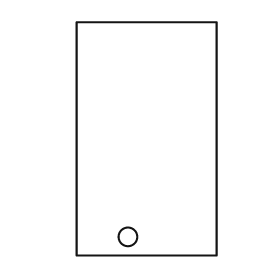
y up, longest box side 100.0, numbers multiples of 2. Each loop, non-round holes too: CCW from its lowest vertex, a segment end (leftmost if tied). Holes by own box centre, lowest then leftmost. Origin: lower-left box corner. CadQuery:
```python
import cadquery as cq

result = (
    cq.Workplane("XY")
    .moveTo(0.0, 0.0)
    .lineTo(60.0, 0.0)
    .lineTo(60.0, 100.0)
    .lineTo(0.0, 100.0)
    .close()
    .moveTo(22.0, 8.0)
    .circle(4.0)
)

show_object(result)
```